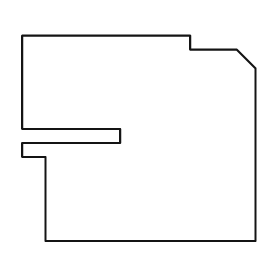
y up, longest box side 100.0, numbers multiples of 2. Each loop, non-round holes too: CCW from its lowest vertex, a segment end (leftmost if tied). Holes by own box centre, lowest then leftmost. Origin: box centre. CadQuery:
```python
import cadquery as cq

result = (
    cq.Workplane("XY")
    .moveTo(-40.0, -44.0)
    .lineTo(50.0, -44.0)
    .lineTo(50.0, 30.0)
    .lineTo(42.0, 38.0)
    .lineTo(22.0, 38.0)
    .lineTo(22.0, 44.0)
    .lineTo(-50.0, 44.0)
    .lineTo(-50.0, 4.0)
    .lineTo(-8.0, 4.0)
    .lineTo(-8.0, -2.0)
    .lineTo(-50.0, -2.0)
    .lineTo(-50.0, -8.0)
    .lineTo(-40.0, -8.0)
    .close()
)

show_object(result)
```